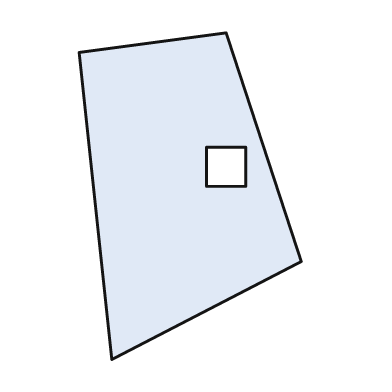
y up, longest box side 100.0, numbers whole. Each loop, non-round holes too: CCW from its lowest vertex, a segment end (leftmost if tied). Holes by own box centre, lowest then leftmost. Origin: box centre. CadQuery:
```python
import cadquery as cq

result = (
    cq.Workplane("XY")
    .moveTo(-24.0, -50.0)
    .lineTo(34.0, -20.0)
    .lineTo(11.0, 50.0)
    .lineTo(-34.0, 44.0)
    .close()
    .moveTo(5.0, 3.0)
    .lineTo(17.0, 3.0)
    .lineTo(17.0, 15.0)
    .lineTo(5.0, 15.0)
    .close()
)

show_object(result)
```